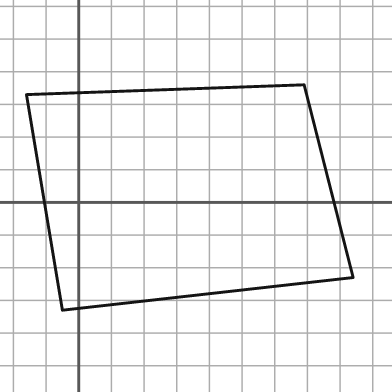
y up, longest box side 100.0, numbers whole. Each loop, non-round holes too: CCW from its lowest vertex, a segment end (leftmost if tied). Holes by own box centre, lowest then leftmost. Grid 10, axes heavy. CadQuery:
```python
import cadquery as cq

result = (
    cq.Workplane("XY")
    .moveTo(-5.0, -33.0)
    .lineTo(84.0, -23.0)
    .lineTo(69.0, 36.0)
    .lineTo(-16.0, 33.0)
    .close()
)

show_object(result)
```